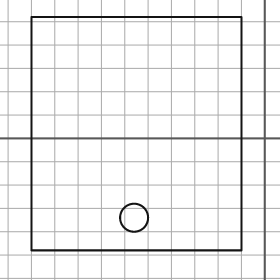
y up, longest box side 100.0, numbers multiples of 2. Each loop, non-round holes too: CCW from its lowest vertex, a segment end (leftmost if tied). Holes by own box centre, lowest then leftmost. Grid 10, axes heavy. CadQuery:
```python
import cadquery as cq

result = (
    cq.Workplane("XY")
    .moveTo(-100.0, -48.0)
    .lineTo(-10.0, -48.0)
    .lineTo(-10.0, 52.0)
    .lineTo(-100.0, 52.0)
    .close()
    .moveTo(-56.0, -34.0)
    .circle(6.0)
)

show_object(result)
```